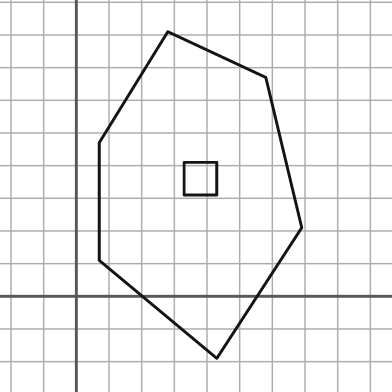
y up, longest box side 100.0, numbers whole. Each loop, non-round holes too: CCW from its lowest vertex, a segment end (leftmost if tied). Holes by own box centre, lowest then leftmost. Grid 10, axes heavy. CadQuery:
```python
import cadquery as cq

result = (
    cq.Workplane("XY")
    .moveTo(43.0, -19.0)
    .lineTo(69.0, 21.0)
    .lineTo(58.0, 67.0)
    .lineTo(28.0, 81.0)
    .lineTo(7.0, 47.0)
    .lineTo(7.0, 11.0)
    .close()
    .moveTo(33.0, 31.0)
    .lineTo(43.0, 31.0)
    .lineTo(43.0, 41.0)
    .lineTo(33.0, 41.0)
    .close()
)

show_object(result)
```